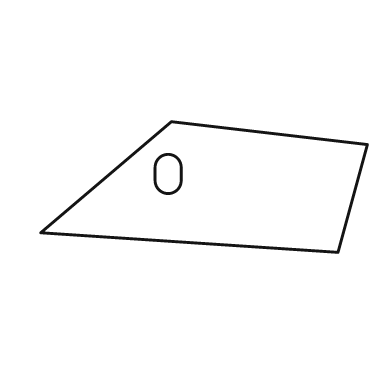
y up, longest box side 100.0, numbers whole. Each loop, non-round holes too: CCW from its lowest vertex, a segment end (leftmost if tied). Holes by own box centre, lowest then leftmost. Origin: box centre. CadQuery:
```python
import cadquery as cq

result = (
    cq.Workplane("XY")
    .moveTo(41.0, -20.0)
    .lineTo(50.0, 13.0)
    .lineTo(-10.0, 20.0)
    .lineTo(-50.0, -14.0)
    .close()
    .moveTo(-15.0, 2.0)
    .threePointArc((-11.0, -2.0), (-7.0, 2.0))
    .lineTo(-7.0, 6.0)
    .threePointArc((-11.0, 10.0), (-15.0, 6.0))
    .close()
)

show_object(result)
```